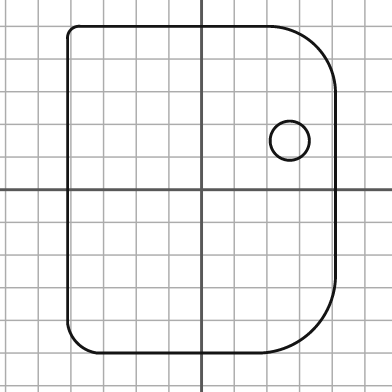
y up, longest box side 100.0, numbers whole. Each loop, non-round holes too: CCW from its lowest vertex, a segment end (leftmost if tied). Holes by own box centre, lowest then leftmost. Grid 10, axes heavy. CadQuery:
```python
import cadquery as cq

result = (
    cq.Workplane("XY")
    .moveTo(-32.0, -50.0)
    .lineTo(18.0, -50.0)
    .threePointArc((34.0, -43.0), (41.0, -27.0))
    .lineTo(41.0, 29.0)
    .threePointArc((35.0, 44.0), (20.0, 50.0))
    .lineTo(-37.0, 50.0)
    .threePointArc((-40.0, 49.0), (-41.0, 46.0))
    .lineTo(-41.0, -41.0)
    .threePointArc((-38.0, -47.0), (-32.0, -50.0))
    .close()
    .moveTo(27.0, 15.0)
    .circle(6.0)
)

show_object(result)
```